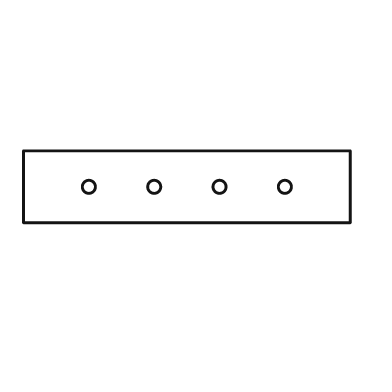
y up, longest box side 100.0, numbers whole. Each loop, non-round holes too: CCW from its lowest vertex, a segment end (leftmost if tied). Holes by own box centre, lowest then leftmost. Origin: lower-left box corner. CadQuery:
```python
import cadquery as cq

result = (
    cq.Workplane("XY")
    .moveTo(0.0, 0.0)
    .lineTo(100.0, 0.0)
    .lineTo(100.0, 22.0)
    .lineTo(0.0, 22.0)
    .close()
    .moveTo(20.0, 11.0)
    .circle(2.0)
    .moveTo(40.0, 11.0)
    .circle(2.0)
    .moveTo(60.0, 11.0)
    .circle(2.0)
    .moveTo(80.0, 11.0)
    .circle(2.0)
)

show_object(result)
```